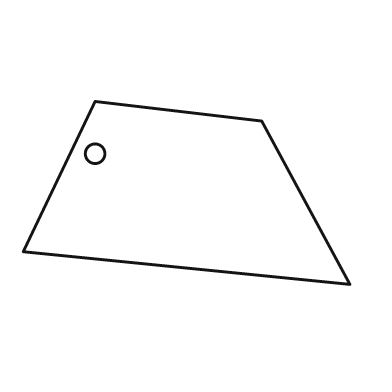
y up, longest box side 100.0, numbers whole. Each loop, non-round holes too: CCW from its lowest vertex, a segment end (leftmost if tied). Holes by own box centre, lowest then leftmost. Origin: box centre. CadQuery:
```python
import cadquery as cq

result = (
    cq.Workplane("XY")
    .moveTo(50.0, -28.0)
    .lineTo(23.0, 22.0)
    .lineTo(-28.0, 28.0)
    .lineTo(-50.0, -18.0)
    .close()
    .moveTo(-28.0, 12.0)
    .circle(3.0)
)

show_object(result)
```